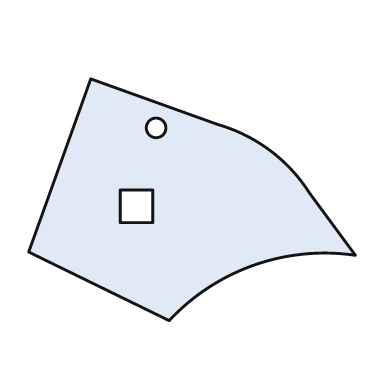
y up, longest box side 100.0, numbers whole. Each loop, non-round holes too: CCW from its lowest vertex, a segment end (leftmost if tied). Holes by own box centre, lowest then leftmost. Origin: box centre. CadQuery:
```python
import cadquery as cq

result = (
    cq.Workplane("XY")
    .moveTo(-7.0, -37.0)
    .threePointArc((19.0, -20.0), (50.0, -17.0))
    .lineTo(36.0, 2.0)
    .threePointArc((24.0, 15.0), (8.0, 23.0))
    .lineTo(-31.0, 37.0)
    .lineTo(-50.0, -16.0)
    .close()
    .moveTo(-22.0, -7.0)
    .lineTo(-12.0, -7.0)
    .lineTo(-12.0, 3.0)
    .lineTo(-22.0, 3.0)
    .close()
    .moveTo(-11.0, 22.0)
    .circle(3.0)
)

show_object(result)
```